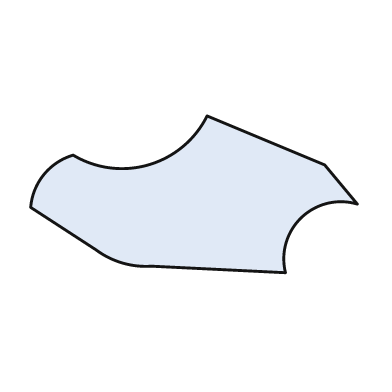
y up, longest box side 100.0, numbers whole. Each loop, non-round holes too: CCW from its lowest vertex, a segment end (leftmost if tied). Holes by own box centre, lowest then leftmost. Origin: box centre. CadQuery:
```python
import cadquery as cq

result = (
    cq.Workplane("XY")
    .moveTo(28.0, -24.0)
    .threePointArc((33.0, -7.0), (50.0, -3.0))
    .lineTo(40.0, 9.0)
    .lineTo(4.0, 24.0)
    .threePointArc((-14.0, 9.0), (-37.0, 12.0))
    .threePointArc((-46.0, 6.0), (-50.0, -4.0))
    .lineTo(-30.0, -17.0)
    .threePointArc((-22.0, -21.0), (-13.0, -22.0))
    .close()
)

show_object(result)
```